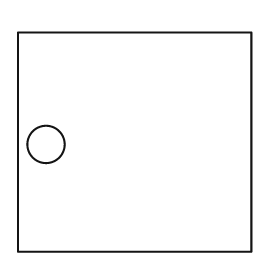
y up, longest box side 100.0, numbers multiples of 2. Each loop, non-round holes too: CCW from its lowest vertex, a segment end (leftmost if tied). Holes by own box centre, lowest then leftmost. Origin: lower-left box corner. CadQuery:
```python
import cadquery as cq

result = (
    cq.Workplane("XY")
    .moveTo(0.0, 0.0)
    .lineTo(100.0, 0.0)
    .lineTo(100.0, 94.0)
    .lineTo(0.0, 94.0)
    .close()
    .moveTo(12.0, 46.0)
    .circle(8.0)
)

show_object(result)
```